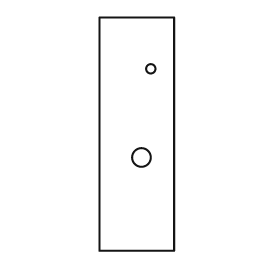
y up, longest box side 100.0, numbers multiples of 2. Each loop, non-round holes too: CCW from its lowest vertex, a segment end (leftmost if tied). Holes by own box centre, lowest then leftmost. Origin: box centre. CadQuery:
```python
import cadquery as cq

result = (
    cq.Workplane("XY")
    .moveTo(-16.0, -50.0)
    .lineTo(16.0, -50.0)
    .lineTo(16.0, 50.0)
    .lineTo(-16.0, 50.0)
    .close()
    .moveTo(2.0, -10.0)
    .circle(4.0)
    .moveTo(6.0, 28.0)
    .circle(2.0)
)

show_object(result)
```